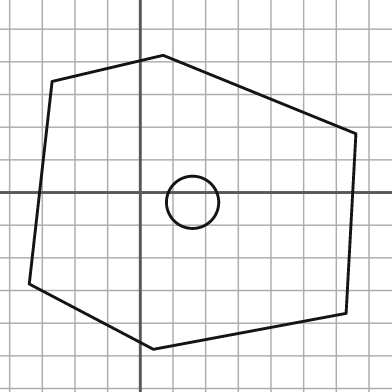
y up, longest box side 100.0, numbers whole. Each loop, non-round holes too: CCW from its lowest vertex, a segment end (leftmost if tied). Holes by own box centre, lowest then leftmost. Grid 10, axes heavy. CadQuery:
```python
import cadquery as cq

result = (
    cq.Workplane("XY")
    .moveTo(4.0, -48.0)
    .lineTo(63.0, -37.0)
    .lineTo(66.0, 18.0)
    .lineTo(7.0, 42.0)
    .lineTo(-27.0, 34.0)
    .lineTo(-34.0, -28.0)
    .close()
    .moveTo(16.0, -3.0)
    .circle(8.0)
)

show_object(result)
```